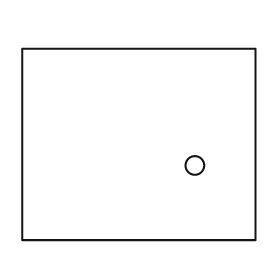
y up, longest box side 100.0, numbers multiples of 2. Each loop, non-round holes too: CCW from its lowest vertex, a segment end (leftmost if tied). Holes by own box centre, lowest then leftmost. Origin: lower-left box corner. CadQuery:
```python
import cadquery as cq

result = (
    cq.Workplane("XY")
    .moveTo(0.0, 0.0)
    .lineTo(100.0, 0.0)
    .lineTo(100.0, 82.0)
    .lineTo(0.0, 82.0)
    .close()
    .moveTo(74.0, 32.0)
    .circle(4.0)
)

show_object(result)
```